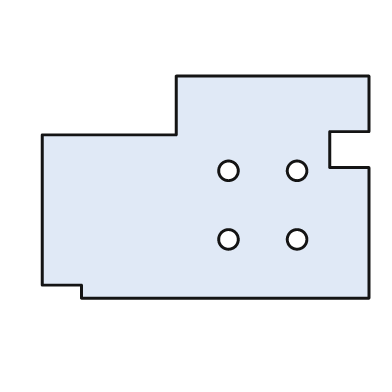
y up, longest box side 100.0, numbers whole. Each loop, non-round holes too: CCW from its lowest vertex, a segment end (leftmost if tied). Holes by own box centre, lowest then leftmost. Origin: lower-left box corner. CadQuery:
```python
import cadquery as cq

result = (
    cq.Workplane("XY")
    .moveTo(12.0, 0.0)
    .lineTo(100.0, 0.0)
    .lineTo(100.0, 40.0)
    .lineTo(88.0, 40.0)
    .lineTo(88.0, 51.0)
    .lineTo(100.0, 51.0)
    .lineTo(100.0, 68.0)
    .lineTo(41.0, 68.0)
    .lineTo(41.0, 50.0)
    .lineTo(0.0, 50.0)
    .lineTo(0.0, 4.0)
    .lineTo(12.0, 4.0)
    .close()
    .moveTo(57.0, 18.0)
    .circle(3.0)
    .moveTo(78.0, 18.0)
    .circle(3.0)
    .moveTo(57.0, 39.0)
    .circle(3.0)
    .moveTo(78.0, 39.0)
    .circle(3.0)
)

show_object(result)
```